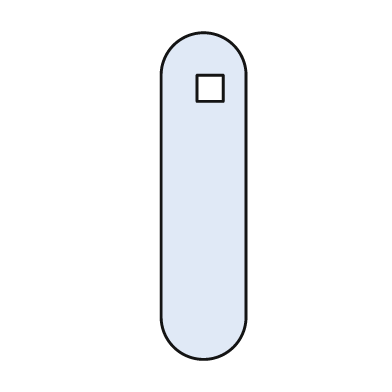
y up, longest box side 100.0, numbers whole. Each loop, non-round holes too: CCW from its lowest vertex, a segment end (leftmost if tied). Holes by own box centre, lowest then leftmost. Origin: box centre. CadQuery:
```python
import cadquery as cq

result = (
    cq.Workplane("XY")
    .moveTo(-13.0, -37.0)
    .threePointArc((0.0, -50.0), (13.0, -37.0))
    .lineTo(13.0, 37.0)
    .threePointArc((0.0, 50.0), (-13.0, 37.0))
    .close()
    .moveTo(-2.0, 29.0)
    .lineTo(6.0, 29.0)
    .lineTo(6.0, 37.0)
    .lineTo(-2.0, 37.0)
    .close()
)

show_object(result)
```